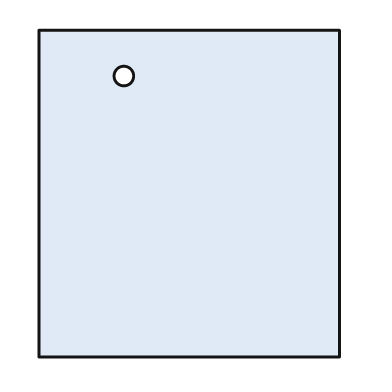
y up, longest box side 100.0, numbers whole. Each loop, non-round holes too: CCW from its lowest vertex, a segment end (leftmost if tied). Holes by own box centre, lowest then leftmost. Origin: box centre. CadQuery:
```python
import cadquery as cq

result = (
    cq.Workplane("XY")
    .moveTo(-46.0, -50.0)
    .lineTo(46.0, -50.0)
    .lineTo(46.0, 50.0)
    .lineTo(-46.0, 50.0)
    .close()
    .moveTo(-20.0, 36.0)
    .circle(3.0)
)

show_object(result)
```